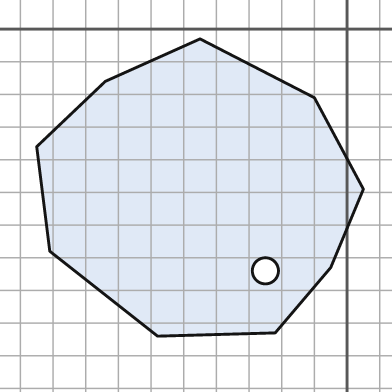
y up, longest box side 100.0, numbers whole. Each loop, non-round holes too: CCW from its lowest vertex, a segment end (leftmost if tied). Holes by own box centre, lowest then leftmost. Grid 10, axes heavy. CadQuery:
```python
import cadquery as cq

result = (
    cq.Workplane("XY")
    .moveTo(-58.0, -94.0)
    .lineTo(-22.0, -93.0)
    .lineTo(-5.0, -73.0)
    .lineTo(5.0, -49.0)
    .lineTo(-10.0, -21.0)
    .lineTo(-45.0, -3.0)
    .lineTo(-74.0, -16.0)
    .lineTo(-95.0, -36.0)
    .lineTo(-91.0, -68.0)
    .close()
    .moveTo(-25.0, -74.0)
    .circle(4.0)
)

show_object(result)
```